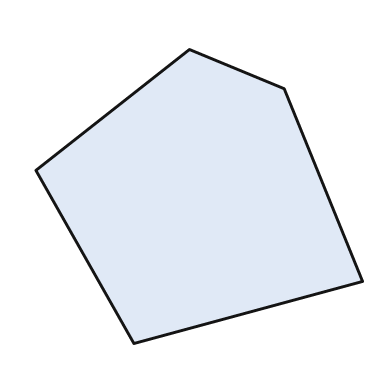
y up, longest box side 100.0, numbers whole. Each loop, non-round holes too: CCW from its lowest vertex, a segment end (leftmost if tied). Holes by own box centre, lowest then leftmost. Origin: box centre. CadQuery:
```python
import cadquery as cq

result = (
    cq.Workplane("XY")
    .moveTo(-20.0, -45.0)
    .lineTo(50.0, -26.0)
    .lineTo(26.0, 33.0)
    .lineTo(-3.0, 45.0)
    .lineTo(-50.0, 8.0)
    .close()
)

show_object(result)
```